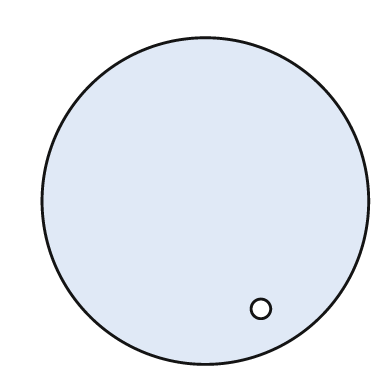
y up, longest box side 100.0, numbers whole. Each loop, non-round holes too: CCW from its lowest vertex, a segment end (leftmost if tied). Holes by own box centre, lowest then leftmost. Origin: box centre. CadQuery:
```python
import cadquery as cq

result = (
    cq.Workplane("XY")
    .moveTo(0.0, 0.0)
    .circle(50.0)
    .moveTo(17.0, -33.0)
    .circle(3.0)
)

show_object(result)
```